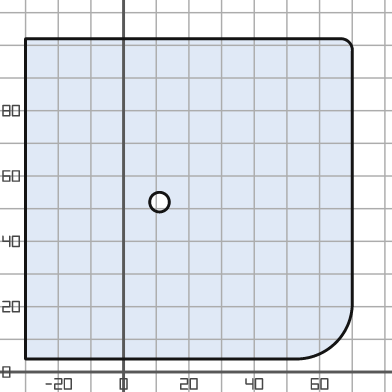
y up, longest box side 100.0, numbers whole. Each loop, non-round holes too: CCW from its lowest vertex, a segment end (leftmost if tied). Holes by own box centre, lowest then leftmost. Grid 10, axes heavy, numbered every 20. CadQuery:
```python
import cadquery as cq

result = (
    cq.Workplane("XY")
    .moveTo(-30.0, 4.0)
    .lineTo(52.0, 4.0)
    .threePointArc((65.0, 9.0), (70.0, 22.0))
    .lineTo(70.0, 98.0)
    .threePointArc((69.0, 101.0), (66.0, 102.0))
    .lineTo(-30.0, 102.0)
    .close()
    .moveTo(11.0, 52.0)
    .circle(3.0)
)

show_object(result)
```